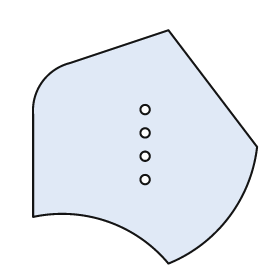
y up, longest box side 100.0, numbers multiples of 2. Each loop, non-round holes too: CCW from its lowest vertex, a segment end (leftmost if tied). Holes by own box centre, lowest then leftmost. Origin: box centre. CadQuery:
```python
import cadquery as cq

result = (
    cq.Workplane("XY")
    .moveTo(10.0, -50.0)
    .threePointArc((36.0, -30.0), (48.0, 0.0))
    .lineTo(10.0, 50.0)
    .lineTo(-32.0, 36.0)
    .threePointArc((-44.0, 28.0), (-48.0, 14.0))
    .lineTo(-48.0, -30.0)
    .threePointArc((-16.0, -32.0), (10.0, -50.0))
    .close()
    .moveTo(0.0, -14.0)
    .circle(2.0)
    .moveTo(0.0, -4.0)
    .circle(2.0)
    .moveTo(0.0, 6.0)
    .circle(2.0)
    .moveTo(0.0, 16.0)
    .circle(2.0)
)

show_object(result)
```